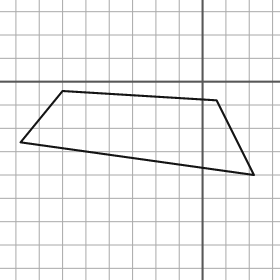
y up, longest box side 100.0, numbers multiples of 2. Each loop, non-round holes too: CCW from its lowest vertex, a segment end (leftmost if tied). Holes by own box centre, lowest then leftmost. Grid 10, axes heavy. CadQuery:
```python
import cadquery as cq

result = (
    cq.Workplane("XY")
    .moveTo(22.0, -40.0)
    .lineTo(6.0, -8.0)
    .lineTo(-60.0, -4.0)
    .lineTo(-78.0, -26.0)
    .close()
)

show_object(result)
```